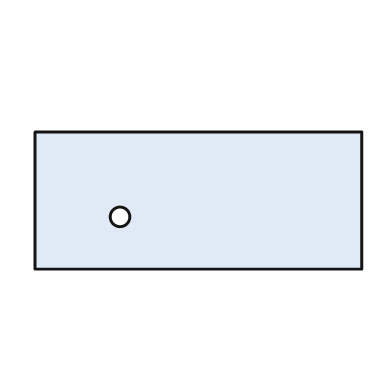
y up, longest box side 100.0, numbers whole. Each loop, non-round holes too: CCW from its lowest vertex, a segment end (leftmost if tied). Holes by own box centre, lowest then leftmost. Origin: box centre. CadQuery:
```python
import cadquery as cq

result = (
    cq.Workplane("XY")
    .moveTo(-50.0, -21.0)
    .lineTo(50.0, -21.0)
    .lineTo(50.0, 21.0)
    .lineTo(-50.0, 21.0)
    .close()
    .moveTo(-24.0, -5.0)
    .circle(3.0)
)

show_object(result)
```